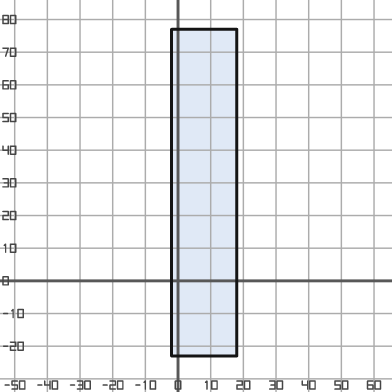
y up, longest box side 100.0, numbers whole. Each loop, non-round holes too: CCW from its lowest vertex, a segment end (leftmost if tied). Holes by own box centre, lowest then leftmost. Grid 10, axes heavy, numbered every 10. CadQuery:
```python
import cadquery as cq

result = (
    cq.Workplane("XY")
    .moveTo(-2.0, -23.0)
    .lineTo(18.0, -23.0)
    .lineTo(18.0, 77.0)
    .lineTo(-2.0, 77.0)
    .close()
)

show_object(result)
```